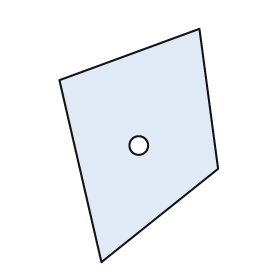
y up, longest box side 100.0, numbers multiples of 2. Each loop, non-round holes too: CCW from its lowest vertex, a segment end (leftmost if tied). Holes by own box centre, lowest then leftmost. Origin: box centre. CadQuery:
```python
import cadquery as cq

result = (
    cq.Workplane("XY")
    .moveTo(-16.0, -50.0)
    .lineTo(34.0, -10.0)
    .lineTo(26.0, 50.0)
    .lineTo(-34.0, 28.0)
    .close()
    .moveTo(0.0, 0.0)
    .circle(4.0)
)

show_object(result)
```